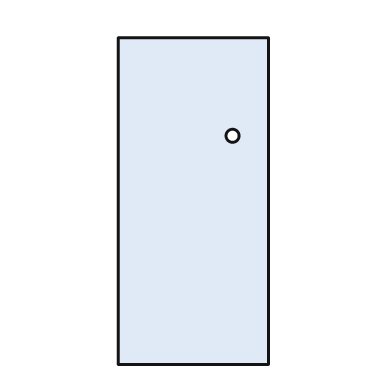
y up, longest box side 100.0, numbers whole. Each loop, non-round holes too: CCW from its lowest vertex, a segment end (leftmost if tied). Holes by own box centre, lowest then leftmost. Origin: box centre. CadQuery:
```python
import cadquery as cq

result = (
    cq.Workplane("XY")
    .moveTo(-23.0, -50.0)
    .lineTo(23.0, -50.0)
    .lineTo(23.0, 50.0)
    .lineTo(-23.0, 50.0)
    .close()
    .moveTo(12.0, 20.0)
    .circle(2.0)
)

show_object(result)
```